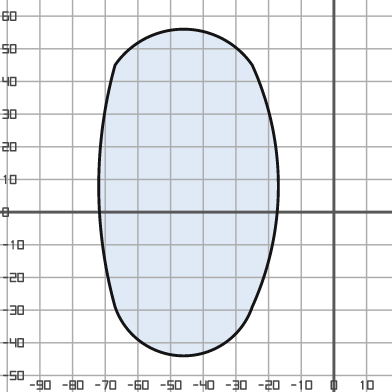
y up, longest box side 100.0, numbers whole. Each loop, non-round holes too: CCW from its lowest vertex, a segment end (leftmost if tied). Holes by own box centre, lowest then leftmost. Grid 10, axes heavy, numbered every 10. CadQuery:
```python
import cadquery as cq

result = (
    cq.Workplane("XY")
    .moveTo(-67.0, -29.0)
    .threePointArc((-46.0, -44.0), (-25.0, -29.0))
    .threePointArc((-17.0, 8.0), (-25.0, 45.0))
    .threePointArc((-46.0, 56.0), (-67.0, 45.0))
    .threePointArc((-72.0, 8.0), (-67.0, -29.0))
    .close()
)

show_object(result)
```